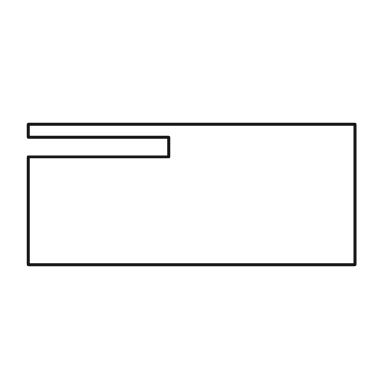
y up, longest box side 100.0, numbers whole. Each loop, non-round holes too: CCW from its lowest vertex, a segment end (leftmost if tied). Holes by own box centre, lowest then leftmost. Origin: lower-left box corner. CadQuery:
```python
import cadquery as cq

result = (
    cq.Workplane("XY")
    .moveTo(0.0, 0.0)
    .lineTo(100.0, 0.0)
    .lineTo(100.0, 43.0)
    .lineTo(0.0, 43.0)
    .lineTo(0.0, 39.0)
    .lineTo(43.0, 39.0)
    .lineTo(43.0, 33.0)
    .lineTo(0.0, 33.0)
    .close()
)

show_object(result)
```